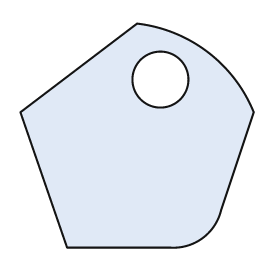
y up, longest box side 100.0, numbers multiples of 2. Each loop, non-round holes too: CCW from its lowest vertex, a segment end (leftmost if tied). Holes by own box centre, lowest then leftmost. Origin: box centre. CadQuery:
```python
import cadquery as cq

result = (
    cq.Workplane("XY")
    .moveTo(-30.0, -48.0)
    .lineTo(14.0, -48.0)
    .threePointArc((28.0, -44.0), (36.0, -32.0))
    .lineTo(50.0, 10.0)
    .threePointArc((30.0, 36.0), (0.0, 48.0))
    .lineTo(-50.0, 10.0)
    .close()
    .moveTo(10.0, 24.0)
    .circle(12.0)
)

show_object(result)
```